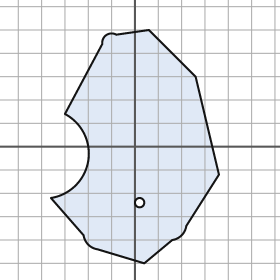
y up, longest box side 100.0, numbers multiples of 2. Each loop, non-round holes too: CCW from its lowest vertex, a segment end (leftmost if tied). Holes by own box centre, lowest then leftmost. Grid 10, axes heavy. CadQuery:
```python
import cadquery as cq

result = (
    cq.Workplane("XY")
    .moveTo(4.0, -50.0)
    .lineTo(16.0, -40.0)
    .threePointArc((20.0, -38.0), (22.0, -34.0))
    .lineTo(36.0, -12.0)
    .lineTo(26.0, 30.0)
    .lineTo(6.0, 50.0)
    .lineTo(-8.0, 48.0)
    .threePointArc((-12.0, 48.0), (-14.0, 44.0))
    .lineTo(-30.0, 14.0)
    .threePointArc((-20.0, -6.0), (-36.0, -22.0))
    .lineTo(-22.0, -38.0)
    .threePointArc((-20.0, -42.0), (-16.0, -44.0))
    .close()
    .moveTo(2.0, -24.0)
    .circle(2.0)
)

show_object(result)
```